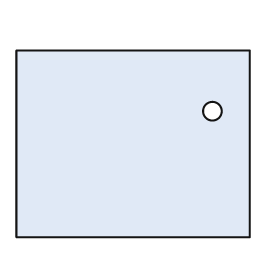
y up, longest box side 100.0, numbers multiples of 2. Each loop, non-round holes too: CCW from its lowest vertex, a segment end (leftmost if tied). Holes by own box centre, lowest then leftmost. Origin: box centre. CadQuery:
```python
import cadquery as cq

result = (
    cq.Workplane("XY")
    .moveTo(-50.0, -40.0)
    .lineTo(50.0, -40.0)
    .lineTo(50.0, 40.0)
    .lineTo(-50.0, 40.0)
    .close()
    .moveTo(34.0, 14.0)
    .circle(4.0)
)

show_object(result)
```